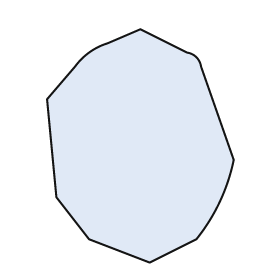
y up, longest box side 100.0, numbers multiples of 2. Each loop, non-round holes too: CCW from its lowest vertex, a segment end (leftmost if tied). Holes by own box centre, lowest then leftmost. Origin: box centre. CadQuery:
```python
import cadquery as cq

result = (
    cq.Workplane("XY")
    .moveTo(4.0, -50.0)
    .lineTo(24.0, -40.0)
    .threePointArc((34.0, -24.0), (40.0, -6.0))
    .lineTo(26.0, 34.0)
    .threePointArc((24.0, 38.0), (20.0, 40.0))
    .lineTo(0.0, 50.0)
    .lineTo(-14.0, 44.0)
    .threePointArc((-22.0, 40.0), (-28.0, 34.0))
    .lineTo(-40.0, 20.0)
    .lineTo(-36.0, -22.0)
    .lineTo(-22.0, -40.0)
    .close()
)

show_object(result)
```